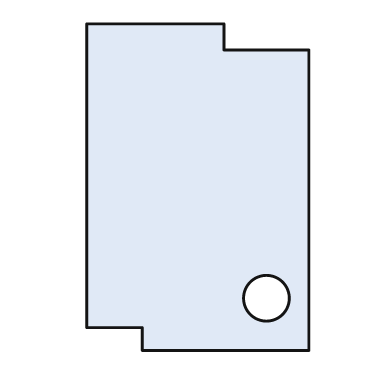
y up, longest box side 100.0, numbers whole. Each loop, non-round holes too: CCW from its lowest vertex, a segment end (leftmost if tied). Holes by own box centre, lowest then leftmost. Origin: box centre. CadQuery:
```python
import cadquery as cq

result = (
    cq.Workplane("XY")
    .moveTo(-17.0, -50.0)
    .lineTo(34.0, -50.0)
    .lineTo(34.0, 42.0)
    .lineTo(8.0, 42.0)
    .lineTo(8.0, 50.0)
    .lineTo(-34.0, 50.0)
    .lineTo(-34.0, -43.0)
    .lineTo(-17.0, -43.0)
    .close()
    .moveTo(21.0, -34.0)
    .circle(7.0)
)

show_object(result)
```